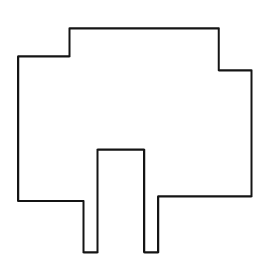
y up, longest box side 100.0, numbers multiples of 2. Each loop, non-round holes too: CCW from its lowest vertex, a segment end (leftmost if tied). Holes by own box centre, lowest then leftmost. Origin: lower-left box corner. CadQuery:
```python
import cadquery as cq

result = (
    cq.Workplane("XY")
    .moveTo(28.0, 0.0)
    .lineTo(34.0, 0.0)
    .lineTo(34.0, 44.0)
    .lineTo(54.0, 44.0)
    .lineTo(54.0, 0.0)
    .lineTo(60.0, 0.0)
    .lineTo(60.0, 24.0)
    .lineTo(100.0, 24.0)
    .lineTo(100.0, 78.0)
    .lineTo(86.0, 78.0)
    .lineTo(86.0, 96.0)
    .lineTo(22.0, 96.0)
    .lineTo(22.0, 84.0)
    .lineTo(0.0, 84.0)
    .lineTo(0.0, 22.0)
    .lineTo(28.0, 22.0)
    .close()
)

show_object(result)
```